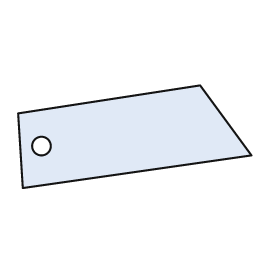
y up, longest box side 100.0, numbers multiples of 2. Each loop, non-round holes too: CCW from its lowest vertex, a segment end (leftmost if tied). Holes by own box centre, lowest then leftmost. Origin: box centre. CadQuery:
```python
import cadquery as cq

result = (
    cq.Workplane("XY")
    .moveTo(-48.0, -22.0)
    .lineTo(50.0, -8.0)
    .lineTo(28.0, 22.0)
    .lineTo(-50.0, 10.0)
    .close()
    .moveTo(-40.0, -4.0)
    .circle(4.0)
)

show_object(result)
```